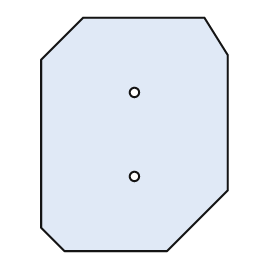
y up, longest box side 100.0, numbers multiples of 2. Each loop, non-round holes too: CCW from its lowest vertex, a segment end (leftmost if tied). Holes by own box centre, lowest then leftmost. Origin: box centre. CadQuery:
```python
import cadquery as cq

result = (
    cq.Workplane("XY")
    .moveTo(-30.0, -50.0)
    .lineTo(14.0, -50.0)
    .lineTo(40.0, -24.0)
    .lineTo(40.0, 34.0)
    .lineTo(30.0, 50.0)
    .lineTo(-22.0, 50.0)
    .lineTo(-40.0, 32.0)
    .lineTo(-40.0, -40.0)
    .close()
    .moveTo(0.0, -18.0)
    .circle(2.0)
    .moveTo(0.0, 18.0)
    .circle(2.0)
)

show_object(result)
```